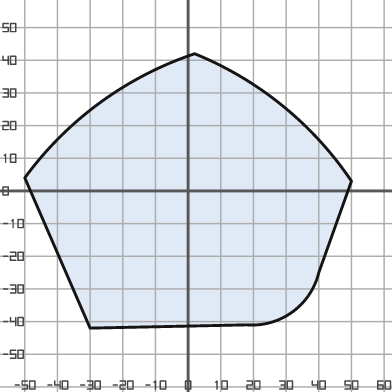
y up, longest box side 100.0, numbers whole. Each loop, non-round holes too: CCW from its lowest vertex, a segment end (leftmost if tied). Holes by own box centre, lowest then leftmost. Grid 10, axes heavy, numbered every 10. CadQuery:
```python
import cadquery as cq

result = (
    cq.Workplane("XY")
    .moveTo(-30.0, -42.0)
    .lineTo(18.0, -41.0)
    .threePointArc((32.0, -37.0), (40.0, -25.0))
    .lineTo(50.0, 3.0)
    .threePointArc((29.0, 26.0), (2.0, 42.0))
    .threePointArc((-27.0, 27.0), (-50.0, 4.0))
    .close()
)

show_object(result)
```